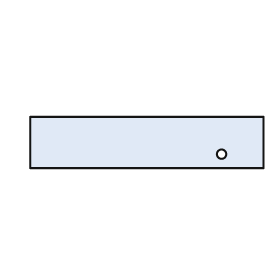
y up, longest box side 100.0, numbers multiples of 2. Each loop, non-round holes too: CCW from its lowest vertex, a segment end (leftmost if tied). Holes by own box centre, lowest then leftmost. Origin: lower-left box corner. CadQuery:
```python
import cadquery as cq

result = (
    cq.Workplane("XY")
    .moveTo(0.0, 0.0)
    .lineTo(100.0, 0.0)
    .lineTo(100.0, 22.0)
    .lineTo(0.0, 22.0)
    .close()
    .moveTo(82.0, 6.0)
    .circle(2.0)
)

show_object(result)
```